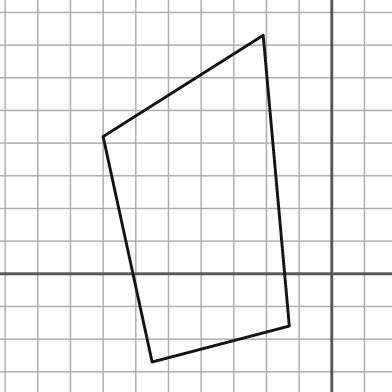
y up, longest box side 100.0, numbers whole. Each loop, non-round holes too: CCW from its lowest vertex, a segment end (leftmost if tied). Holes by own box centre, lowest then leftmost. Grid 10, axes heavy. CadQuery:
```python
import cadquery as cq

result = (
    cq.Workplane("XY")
    .moveTo(-55.0, -27.0)
    .lineTo(-13.0, -16.0)
    .lineTo(-21.0, 73.0)
    .lineTo(-70.0, 42.0)
    .close()
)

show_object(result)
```